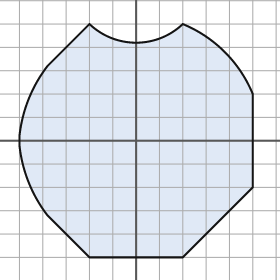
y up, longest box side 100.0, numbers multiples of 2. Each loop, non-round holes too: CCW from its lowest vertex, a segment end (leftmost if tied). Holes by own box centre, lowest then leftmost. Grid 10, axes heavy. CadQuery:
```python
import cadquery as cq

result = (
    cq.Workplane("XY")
    .moveTo(-20.0, -50.0)
    .lineTo(20.0, -50.0)
    .lineTo(50.0, -20.0)
    .lineTo(50.0, 20.0)
    .threePointArc((38.0, 38.0), (20.0, 50.0))
    .threePointArc((0.0, 42.0), (-20.0, 50.0))
    .lineTo(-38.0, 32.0)
    .threePointArc((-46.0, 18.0), (-50.0, 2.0))
    .lineTo(-50.0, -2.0)
    .threePointArc((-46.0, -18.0), (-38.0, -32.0))
    .close()
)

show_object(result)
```